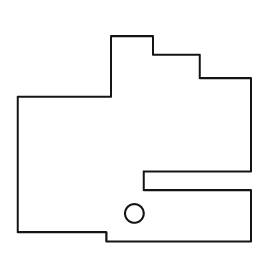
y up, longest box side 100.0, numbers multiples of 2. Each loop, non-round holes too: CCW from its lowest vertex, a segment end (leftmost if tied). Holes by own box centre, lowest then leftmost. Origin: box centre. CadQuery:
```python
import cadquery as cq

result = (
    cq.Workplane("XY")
    .moveTo(-12.0, -44.0)
    .lineTo(50.0, -44.0)
    .lineTo(50.0, -22.0)
    .lineTo(4.0, -22.0)
    .lineTo(4.0, -14.0)
    .lineTo(50.0, -14.0)
    .lineTo(50.0, 26.0)
    .lineTo(28.0, 26.0)
    .lineTo(28.0, 36.0)
    .lineTo(8.0, 36.0)
    .lineTo(8.0, 44.0)
    .lineTo(-10.0, 44.0)
    .lineTo(-10.0, 18.0)
    .lineTo(-50.0, 18.0)
    .lineTo(-50.0, -40.0)
    .lineTo(-12.0, -40.0)
    .close()
    .moveTo(0.0, -32.0)
    .circle(4.0)
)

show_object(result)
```